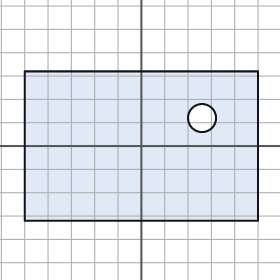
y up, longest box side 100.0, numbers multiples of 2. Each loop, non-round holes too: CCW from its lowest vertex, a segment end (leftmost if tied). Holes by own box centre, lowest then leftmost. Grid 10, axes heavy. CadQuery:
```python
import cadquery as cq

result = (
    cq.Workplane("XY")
    .moveTo(-50.0, -32.0)
    .lineTo(50.0, -32.0)
    .lineTo(50.0, 32.0)
    .lineTo(-50.0, 32.0)
    .close()
    .moveTo(26.0, 12.0)
    .circle(6.0)
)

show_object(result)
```